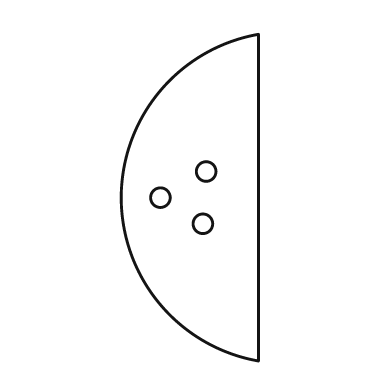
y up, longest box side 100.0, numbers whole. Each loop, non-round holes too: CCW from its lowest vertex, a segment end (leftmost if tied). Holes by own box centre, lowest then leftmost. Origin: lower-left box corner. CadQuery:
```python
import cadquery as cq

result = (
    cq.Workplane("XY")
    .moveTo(42.0, 0.0)
    .lineTo(42.0, 100.0)
    .threePointArc((0.0, 50.0), (42.0, 0.0))
    .close()
    .moveTo(25.0, 42.0)
    .circle(3.0)
    .moveTo(12.0, 50.0)
    .circle(3.0)
    .moveTo(26.0, 58.0)
    .circle(3.0)
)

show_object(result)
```